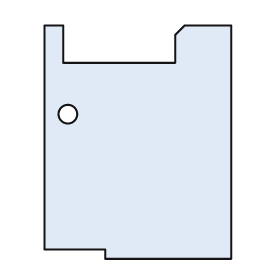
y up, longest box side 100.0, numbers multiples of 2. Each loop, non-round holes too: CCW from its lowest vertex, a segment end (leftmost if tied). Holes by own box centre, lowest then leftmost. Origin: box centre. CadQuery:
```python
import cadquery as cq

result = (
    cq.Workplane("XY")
    .moveTo(-14.0, -50.0)
    .lineTo(40.0, -50.0)
    .lineTo(40.0, 50.0)
    .lineTo(20.0, 50.0)
    .lineTo(16.0, 46.0)
    .lineTo(16.0, 34.0)
    .lineTo(-32.0, 34.0)
    .lineTo(-32.0, 50.0)
    .lineTo(-40.0, 50.0)
    .lineTo(-40.0, -46.0)
    .lineTo(-14.0, -46.0)
    .close()
    .moveTo(-30.0, 12.0)
    .circle(4.0)
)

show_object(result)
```